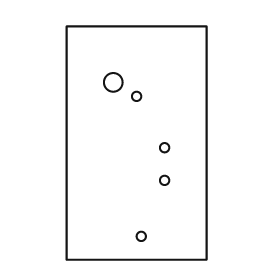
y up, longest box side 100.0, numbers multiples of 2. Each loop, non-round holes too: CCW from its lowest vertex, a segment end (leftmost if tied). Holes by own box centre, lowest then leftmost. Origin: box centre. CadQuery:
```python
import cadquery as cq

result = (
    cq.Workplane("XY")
    .moveTo(-30.0, -50.0)
    .lineTo(30.0, -50.0)
    .lineTo(30.0, 50.0)
    .lineTo(-30.0, 50.0)
    .close()
    .moveTo(2.0, -40.0)
    .circle(2.0)
    .moveTo(12.0, -16.0)
    .circle(2.0)
    .moveTo(12.0, -2.0)
    .circle(2.0)
    .moveTo(0.0, 20.0)
    .circle(2.0)
    .moveTo(-10.0, 26.0)
    .circle(4.0)
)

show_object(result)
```